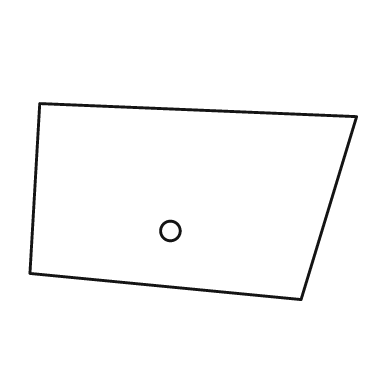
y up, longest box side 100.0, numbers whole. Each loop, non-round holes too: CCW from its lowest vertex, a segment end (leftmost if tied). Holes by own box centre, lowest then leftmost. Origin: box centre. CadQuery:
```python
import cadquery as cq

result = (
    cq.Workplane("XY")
    .moveTo(33.0, -30.0)
    .lineTo(50.0, 26.0)
    .lineTo(-47.0, 30.0)
    .lineTo(-50.0, -22.0)
    .close()
    .moveTo(-7.0, -9.0)
    .circle(3.0)
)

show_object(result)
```